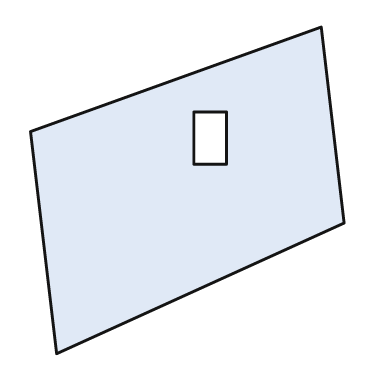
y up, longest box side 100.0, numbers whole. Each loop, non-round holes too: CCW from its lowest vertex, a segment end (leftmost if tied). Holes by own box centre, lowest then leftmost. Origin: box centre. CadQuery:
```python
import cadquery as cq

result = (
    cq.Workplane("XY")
    .moveTo(-40.0, -50.0)
    .lineTo(48.0, -10.0)
    .lineTo(41.0, 50.0)
    .lineTo(-48.0, 18.0)
    .close()
    .moveTo(2.0, 8.0)
    .lineTo(12.0, 8.0)
    .lineTo(12.0, 24.0)
    .lineTo(2.0, 24.0)
    .close()
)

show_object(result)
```